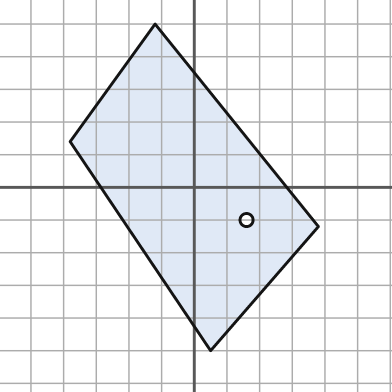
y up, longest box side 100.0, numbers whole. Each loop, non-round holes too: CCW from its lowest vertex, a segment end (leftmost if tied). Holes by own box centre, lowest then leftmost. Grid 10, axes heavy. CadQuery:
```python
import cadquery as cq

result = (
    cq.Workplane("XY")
    .moveTo(5.0, -50.0)
    .lineTo(38.0, -12.0)
    .lineTo(-12.0, 50.0)
    .lineTo(-38.0, 14.0)
    .close()
    .moveTo(16.0, -10.0)
    .circle(2.0)
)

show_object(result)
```